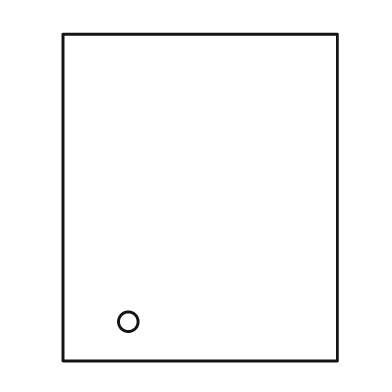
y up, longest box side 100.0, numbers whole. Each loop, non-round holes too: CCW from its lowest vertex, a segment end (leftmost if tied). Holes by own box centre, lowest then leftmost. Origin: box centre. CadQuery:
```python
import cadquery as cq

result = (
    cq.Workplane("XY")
    .moveTo(-42.0, -50.0)
    .lineTo(42.0, -50.0)
    .lineTo(42.0, 50.0)
    .lineTo(-42.0, 50.0)
    .close()
    .moveTo(-22.0, -38.0)
    .circle(3.0)
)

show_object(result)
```